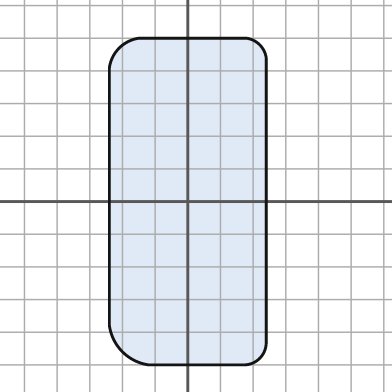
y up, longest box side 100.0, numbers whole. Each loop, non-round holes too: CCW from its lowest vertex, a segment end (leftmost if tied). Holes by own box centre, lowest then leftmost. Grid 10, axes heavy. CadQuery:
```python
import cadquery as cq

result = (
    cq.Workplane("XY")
    .moveTo(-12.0, -50.0)
    .lineTo(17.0, -50.0)
    .threePointArc((22.0, -48.0), (24.0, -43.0))
    .lineTo(24.0, 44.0)
    .threePointArc((22.0, 48.0), (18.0, 50.0))
    .lineTo(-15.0, 50.0)
    .threePointArc((-21.0, 47.0), (-24.0, 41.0))
    .lineTo(-24.0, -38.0)
    .threePointArc((-20.0, -46.0), (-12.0, -50.0))
    .close()
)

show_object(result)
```